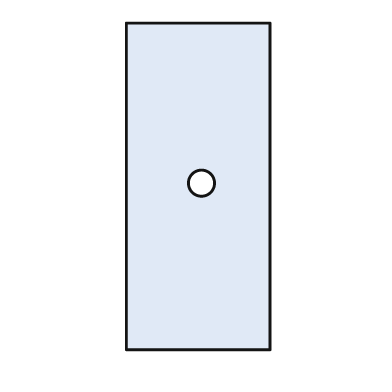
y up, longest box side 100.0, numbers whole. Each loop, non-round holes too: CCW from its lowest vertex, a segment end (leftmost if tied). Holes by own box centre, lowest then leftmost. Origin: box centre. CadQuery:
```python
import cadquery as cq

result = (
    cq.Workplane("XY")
    .moveTo(-22.0, -50.0)
    .lineTo(22.0, -50.0)
    .lineTo(22.0, 50.0)
    .lineTo(-22.0, 50.0)
    .close()
    .moveTo(1.0, 1.0)
    .circle(4.0)
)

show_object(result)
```